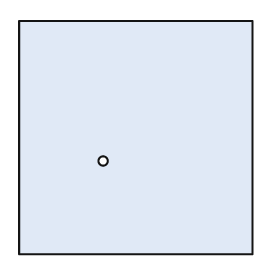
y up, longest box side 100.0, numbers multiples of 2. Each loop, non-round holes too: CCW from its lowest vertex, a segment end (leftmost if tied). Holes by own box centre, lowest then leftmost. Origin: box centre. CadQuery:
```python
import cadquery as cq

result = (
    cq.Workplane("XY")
    .moveTo(-50.0, -50.0)
    .lineTo(50.0, -50.0)
    .lineTo(50.0, 50.0)
    .lineTo(-50.0, 50.0)
    .close()
    .moveTo(-14.0, -10.0)
    .circle(2.0)
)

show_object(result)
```